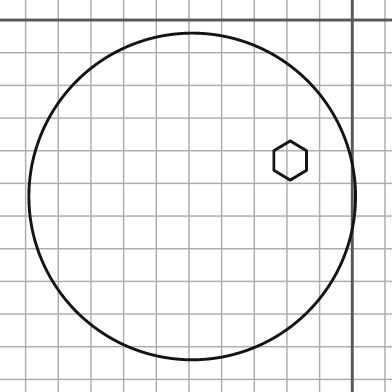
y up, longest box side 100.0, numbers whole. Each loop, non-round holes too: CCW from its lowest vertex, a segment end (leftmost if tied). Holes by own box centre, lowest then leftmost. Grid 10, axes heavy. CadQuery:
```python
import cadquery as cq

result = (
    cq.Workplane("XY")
    .moveTo(-49.0, -54.0)
    .circle(50.0)
    .moveTo(-19.0, -49.0)
    .lineTo(-14.0, -46.0)
    .lineTo(-14.0, -40.0)
    .lineTo(-19.0, -37.0)
    .lineTo(-24.0, -40.0)
    .lineTo(-24.0, -46.0)
    .close()
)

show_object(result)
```